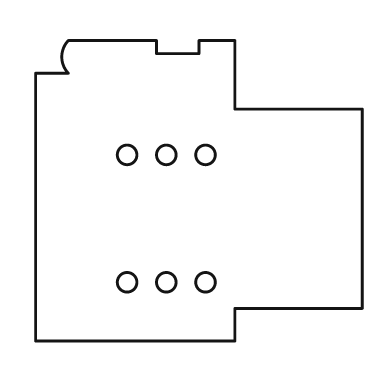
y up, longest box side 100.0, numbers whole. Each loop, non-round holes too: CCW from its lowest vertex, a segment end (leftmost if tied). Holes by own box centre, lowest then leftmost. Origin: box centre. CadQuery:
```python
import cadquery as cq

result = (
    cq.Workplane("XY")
    .moveTo(-50.0, -46.0)
    .lineTo(11.0, -46.0)
    .lineTo(11.0, -36.0)
    .lineTo(50.0, -36.0)
    .lineTo(50.0, 25.0)
    .lineTo(11.0, 25.0)
    .lineTo(11.0, 46.0)
    .lineTo(0.0, 46.0)
    .lineTo(0.0, 42.0)
    .lineTo(-13.0, 42.0)
    .lineTo(-13.0, 46.0)
    .lineTo(-40.0, 46.0)
    .threePointArc((-42.0, 41.0), (-40.0, 36.0))
    .lineTo(-50.0, 36.0)
    .close()
    .moveTo(-22.0, -28.0)
    .circle(3.0)
    .moveTo(-10.0, -28.0)
    .circle(3.0)
    .moveTo(2.0, -28.0)
    .circle(3.0)
    .moveTo(-22.0, 11.0)
    .circle(3.0)
    .moveTo(-10.0, 11.0)
    .circle(3.0)
    .moveTo(2.0, 11.0)
    .circle(3.0)
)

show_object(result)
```